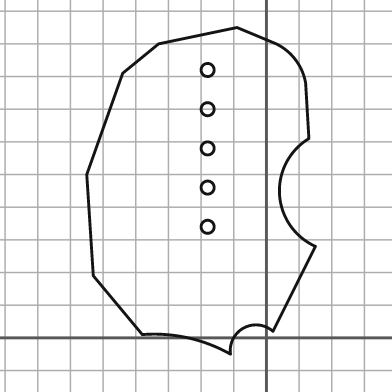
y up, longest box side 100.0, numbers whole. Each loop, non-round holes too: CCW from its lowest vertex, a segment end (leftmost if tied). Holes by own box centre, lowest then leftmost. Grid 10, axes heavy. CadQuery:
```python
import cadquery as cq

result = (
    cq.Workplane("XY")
    .moveTo(-11.0, -5.0)
    .threePointArc((-7.0, 3.0), (2.0, 2.0))
    .lineTo(15.0, 28.0)
    .threePointArc((4.0, 44.0), (13.0, 61.0))
    .lineTo(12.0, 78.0)
    .threePointArc((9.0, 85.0), (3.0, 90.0))
    .lineTo(-9.0, 95.0)
    .lineTo(-33.0, 90.0)
    .lineTo(-44.0, 81.0)
    .lineTo(-55.0, 50.0)
    .lineTo(-53.0, 19.0)
    .lineTo(-38.0, 1.0)
    .threePointArc((-24.0, 0.0), (-11.0, -5.0))
    .close()
    .moveTo(-18.0, 34.0)
    .circle(2.0)
    .moveTo(-18.0, 46.0)
    .circle(2.0)
    .moveTo(-18.0, 58.0)
    .circle(2.0)
    .moveTo(-18.0, 70.0)
    .circle(2.0)
    .moveTo(-18.0, 82.0)
    .circle(2.0)
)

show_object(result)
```